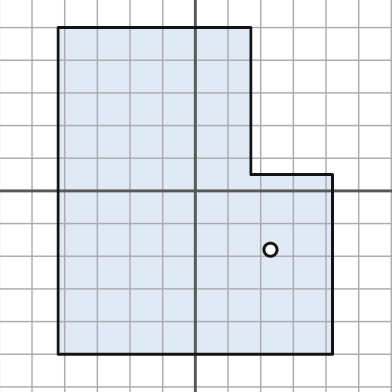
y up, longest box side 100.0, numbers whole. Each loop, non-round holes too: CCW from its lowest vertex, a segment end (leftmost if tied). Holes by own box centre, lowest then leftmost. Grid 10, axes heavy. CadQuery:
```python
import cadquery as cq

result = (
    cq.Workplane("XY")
    .moveTo(-42.0, -50.0)
    .lineTo(42.0, -50.0)
    .lineTo(42.0, 5.0)
    .lineTo(17.0, 5.0)
    .lineTo(17.0, 50.0)
    .lineTo(-42.0, 50.0)
    .close()
    .moveTo(23.0, -18.0)
    .circle(2.0)
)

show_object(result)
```